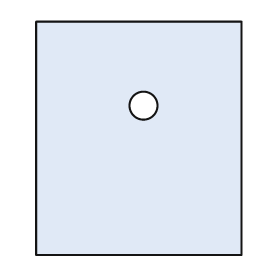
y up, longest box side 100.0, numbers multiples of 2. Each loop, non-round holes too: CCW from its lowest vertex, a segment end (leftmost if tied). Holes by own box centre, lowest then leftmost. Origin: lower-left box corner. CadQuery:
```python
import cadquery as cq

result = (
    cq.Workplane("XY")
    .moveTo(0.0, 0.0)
    .lineTo(88.0, 0.0)
    .lineTo(88.0, 100.0)
    .lineTo(0.0, 100.0)
    .close()
    .moveTo(46.0, 64.0)
    .circle(6.0)
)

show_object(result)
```